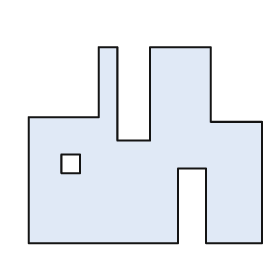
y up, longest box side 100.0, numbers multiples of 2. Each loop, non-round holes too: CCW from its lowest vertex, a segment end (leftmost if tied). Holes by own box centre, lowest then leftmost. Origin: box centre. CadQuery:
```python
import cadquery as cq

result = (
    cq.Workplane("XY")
    .moveTo(-50.0, -42.0)
    .lineTo(14.0, -42.0)
    .lineTo(14.0, -10.0)
    .lineTo(26.0, -10.0)
    .lineTo(26.0, -42.0)
    .lineTo(50.0, -42.0)
    .lineTo(50.0, 10.0)
    .lineTo(28.0, 10.0)
    .lineTo(28.0, 42.0)
    .lineTo(2.0, 42.0)
    .lineTo(2.0, 2.0)
    .lineTo(-12.0, 2.0)
    .lineTo(-12.0, 42.0)
    .lineTo(-20.0, 42.0)
    .lineTo(-20.0, 12.0)
    .lineTo(-50.0, 12.0)
    .close()
    .moveTo(-36.0, -12.0)
    .lineTo(-28.0, -12.0)
    .lineTo(-28.0, -4.0)
    .lineTo(-36.0, -4.0)
    .close()
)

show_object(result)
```